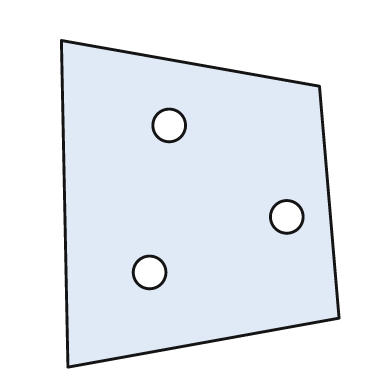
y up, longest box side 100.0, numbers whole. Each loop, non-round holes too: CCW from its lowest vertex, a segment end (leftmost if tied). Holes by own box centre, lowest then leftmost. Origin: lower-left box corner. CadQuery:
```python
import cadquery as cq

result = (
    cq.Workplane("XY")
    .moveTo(2.0, 0.0)
    .lineTo(85.0, 15.0)
    .lineTo(79.0, 86.0)
    .lineTo(0.0, 100.0)
    .close()
    .moveTo(27.0, 29.0)
    .circle(5.0)
    .moveTo(69.0, 46.0)
    .circle(5.0)
    .moveTo(33.0, 74.0)
    .circle(5.0)
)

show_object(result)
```